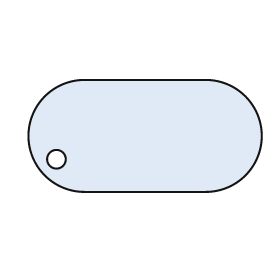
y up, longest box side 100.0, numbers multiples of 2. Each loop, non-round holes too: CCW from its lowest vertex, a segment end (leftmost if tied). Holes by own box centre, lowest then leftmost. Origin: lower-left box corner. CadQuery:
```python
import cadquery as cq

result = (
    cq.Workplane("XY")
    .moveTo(24.0, 0.0)
    .lineTo(76.0, 0.0)
    .threePointArc((100.0, 24.0), (76.0, 48.0))
    .lineTo(24.0, 48.0)
    .threePointArc((0.0, 24.0), (24.0, 0.0))
    .close()
    .moveTo(12.0, 14.0)
    .circle(4.0)
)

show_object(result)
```